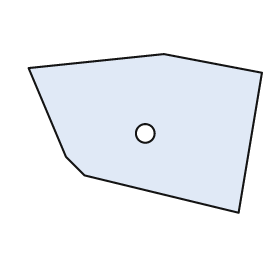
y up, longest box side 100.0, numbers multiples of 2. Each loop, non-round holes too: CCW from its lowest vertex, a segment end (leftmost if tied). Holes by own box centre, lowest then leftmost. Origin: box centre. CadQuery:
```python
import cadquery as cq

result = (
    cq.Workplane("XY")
    .moveTo(40.0, -34.0)
    .lineTo(50.0, 26.0)
    .lineTo(8.0, 34.0)
    .lineTo(-50.0, 28.0)
    .lineTo(-34.0, -10.0)
    .lineTo(-26.0, -18.0)
    .close()
    .moveTo(0.0, 0.0)
    .circle(4.0)
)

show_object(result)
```